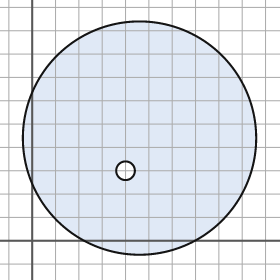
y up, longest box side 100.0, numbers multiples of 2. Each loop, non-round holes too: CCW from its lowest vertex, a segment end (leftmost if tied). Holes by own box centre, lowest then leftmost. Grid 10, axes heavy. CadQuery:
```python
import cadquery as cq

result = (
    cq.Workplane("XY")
    .moveTo(46.0, 44.0)
    .circle(50.0)
    .moveTo(40.0, 30.0)
    .circle(4.0)
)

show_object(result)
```